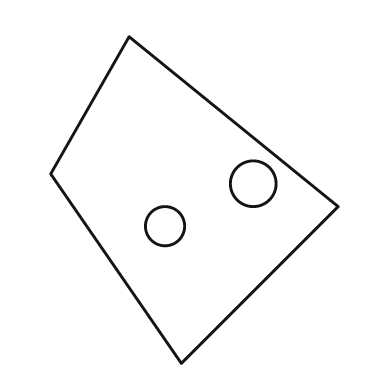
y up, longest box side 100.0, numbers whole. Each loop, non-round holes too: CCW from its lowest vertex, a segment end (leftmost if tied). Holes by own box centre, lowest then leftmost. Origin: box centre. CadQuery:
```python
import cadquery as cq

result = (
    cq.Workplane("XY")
    .moveTo(-4.0, -50.0)
    .lineTo(44.0, -2.0)
    .lineTo(-20.0, 50.0)
    .lineTo(-44.0, 8.0)
    .close()
    .moveTo(-9.0, -8.0)
    .circle(6.0)
    .moveTo(18.0, 5.0)
    .circle(7.0)
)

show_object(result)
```